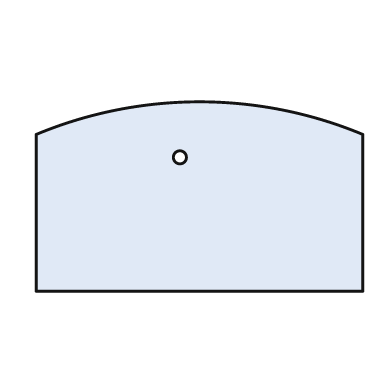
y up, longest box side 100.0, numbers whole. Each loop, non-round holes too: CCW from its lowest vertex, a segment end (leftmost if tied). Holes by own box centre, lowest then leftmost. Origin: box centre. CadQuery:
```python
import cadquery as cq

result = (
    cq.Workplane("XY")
    .moveTo(-50.0, -29.0)
    .lineTo(50.0, -29.0)
    .lineTo(50.0, 19.0)
    .threePointArc((0.0, 29.0), (-50.0, 19.0))
    .close()
    .moveTo(-6.0, 12.0)
    .circle(2.0)
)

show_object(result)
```